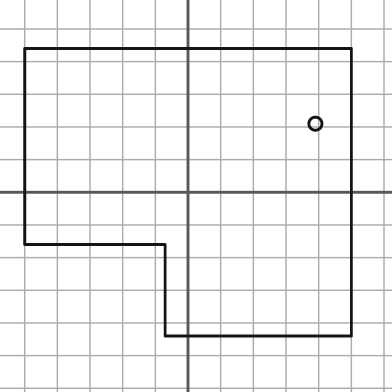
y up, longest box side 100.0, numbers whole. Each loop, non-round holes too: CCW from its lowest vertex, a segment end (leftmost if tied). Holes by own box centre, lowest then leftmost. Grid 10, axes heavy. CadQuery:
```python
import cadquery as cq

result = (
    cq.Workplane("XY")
    .moveTo(-7.0, -44.0)
    .lineTo(50.0, -44.0)
    .lineTo(50.0, 44.0)
    .lineTo(-50.0, 44.0)
    .lineTo(-50.0, -16.0)
    .lineTo(-7.0, -16.0)
    .close()
    .moveTo(39.0, 21.0)
    .circle(2.0)
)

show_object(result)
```